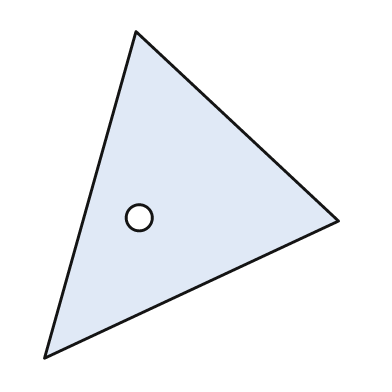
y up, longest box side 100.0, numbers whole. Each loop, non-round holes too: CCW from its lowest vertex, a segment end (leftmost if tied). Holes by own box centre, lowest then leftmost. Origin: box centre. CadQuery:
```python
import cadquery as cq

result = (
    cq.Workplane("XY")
    .moveTo(-45.0, -50.0)
    .lineTo(45.0, -8.0)
    .lineTo(-17.0, 50.0)
    .close()
    .moveTo(-16.0, -7.0)
    .circle(4.0)
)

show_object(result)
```